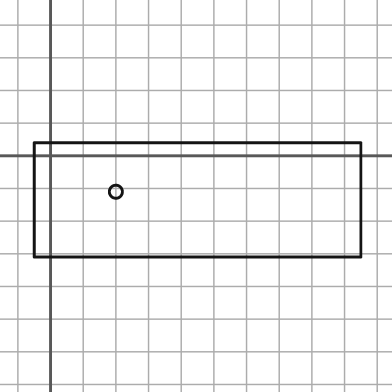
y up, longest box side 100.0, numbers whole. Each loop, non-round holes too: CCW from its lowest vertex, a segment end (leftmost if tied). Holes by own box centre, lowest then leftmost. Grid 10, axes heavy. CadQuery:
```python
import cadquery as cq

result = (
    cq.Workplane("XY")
    .moveTo(-5.0, -31.0)
    .lineTo(95.0, -31.0)
    .lineTo(95.0, 4.0)
    .lineTo(-5.0, 4.0)
    .close()
    .moveTo(20.0, -11.0)
    .circle(2.0)
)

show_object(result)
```